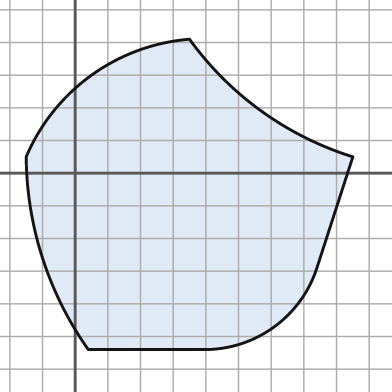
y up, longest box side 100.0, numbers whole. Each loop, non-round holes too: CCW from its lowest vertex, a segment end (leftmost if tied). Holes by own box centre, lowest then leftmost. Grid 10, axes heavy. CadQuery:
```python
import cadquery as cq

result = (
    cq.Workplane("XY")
    .moveTo(4.0, -54.0)
    .lineTo(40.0, -54.0)
    .threePointArc((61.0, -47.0), (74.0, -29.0))
    .lineTo(85.0, 5.0)
    .threePointArc((57.0, 19.0), (35.0, 41.0))
    .threePointArc((5.0, 30.0), (-15.0, 5.0))
    .threePointArc((-10.0, -26.0), (4.0, -54.0))
    .close()
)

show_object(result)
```